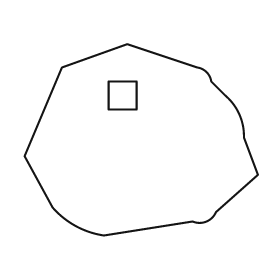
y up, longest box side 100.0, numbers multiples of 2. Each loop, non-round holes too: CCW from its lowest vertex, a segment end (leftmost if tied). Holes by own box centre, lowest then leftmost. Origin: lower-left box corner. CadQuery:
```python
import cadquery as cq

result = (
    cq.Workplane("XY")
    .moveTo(34.0, 0.0)
    .lineTo(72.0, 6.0)
    .threePointArc((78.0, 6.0), (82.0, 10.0))
    .lineTo(100.0, 26.0)
    .lineTo(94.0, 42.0)
    .threePointArc((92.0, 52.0), (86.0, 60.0))
    .lineTo(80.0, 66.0)
    .threePointArc((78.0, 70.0), (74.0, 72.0))
    .lineTo(44.0, 82.0)
    .lineTo(16.0, 72.0)
    .lineTo(0.0, 34.0)
    .lineTo(12.0, 12.0)
    .threePointArc((22.0, 4.0), (34.0, 0.0))
    .close()
    .moveTo(36.0, 54.0)
    .lineTo(48.0, 54.0)
    .lineTo(48.0, 66.0)
    .lineTo(36.0, 66.0)
    .close()
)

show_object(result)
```